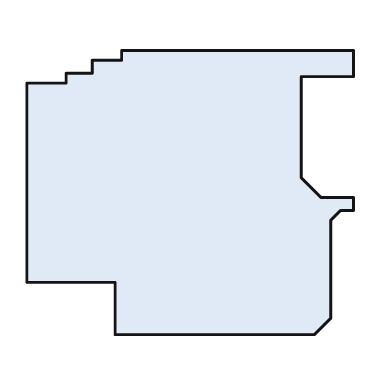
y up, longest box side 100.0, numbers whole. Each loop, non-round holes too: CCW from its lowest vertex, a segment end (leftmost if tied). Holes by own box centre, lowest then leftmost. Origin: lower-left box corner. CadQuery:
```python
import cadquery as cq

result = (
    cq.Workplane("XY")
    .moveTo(27.0, 0.0)
    .lineTo(88.0, 0.0)
    .lineTo(93.0, 5.0)
    .lineTo(93.0, 35.0)
    .lineTo(96.0, 38.0)
    .lineTo(100.0, 38.0)
    .lineTo(100.0, 42.0)
    .lineTo(90.0, 42.0)
    .lineTo(84.0, 48.0)
    .lineTo(84.0, 79.0)
    .lineTo(100.0, 79.0)
    .lineTo(100.0, 87.0)
    .lineTo(29.0, 87.0)
    .lineTo(29.0, 84.0)
    .lineTo(20.0, 84.0)
    .lineTo(20.0, 80.0)
    .lineTo(12.0, 80.0)
    .lineTo(12.0, 77.0)
    .lineTo(0.0, 77.0)
    .lineTo(0.0, 16.0)
    .lineTo(27.0, 16.0)
    .close()
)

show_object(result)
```